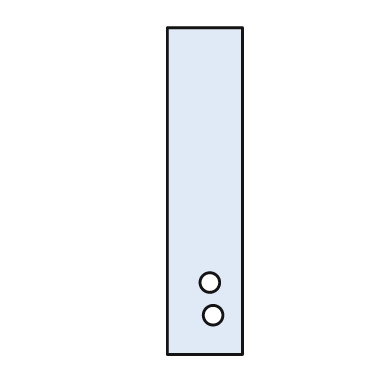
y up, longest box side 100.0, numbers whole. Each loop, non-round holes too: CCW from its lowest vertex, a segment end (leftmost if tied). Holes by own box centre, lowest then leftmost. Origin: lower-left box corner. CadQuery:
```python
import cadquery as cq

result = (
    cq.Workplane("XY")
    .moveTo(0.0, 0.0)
    .lineTo(23.0, 0.0)
    .lineTo(23.0, 100.0)
    .lineTo(0.0, 100.0)
    .close()
    .moveTo(14.0, 12.0)
    .circle(3.0)
    .moveTo(13.0, 22.0)
    .circle(3.0)
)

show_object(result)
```